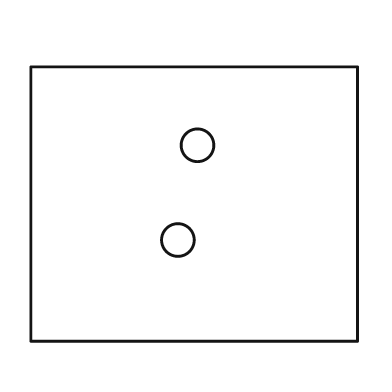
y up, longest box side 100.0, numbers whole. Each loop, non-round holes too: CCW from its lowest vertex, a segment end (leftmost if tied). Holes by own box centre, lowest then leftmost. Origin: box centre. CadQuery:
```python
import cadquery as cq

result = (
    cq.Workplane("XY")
    .moveTo(-50.0, -42.0)
    .lineTo(50.0, -42.0)
    .lineTo(50.0, 42.0)
    .lineTo(-50.0, 42.0)
    .close()
    .moveTo(-5.0, -11.0)
    .circle(5.0)
    .moveTo(1.0, 18.0)
    .circle(5.0)
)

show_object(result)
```